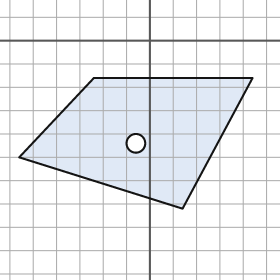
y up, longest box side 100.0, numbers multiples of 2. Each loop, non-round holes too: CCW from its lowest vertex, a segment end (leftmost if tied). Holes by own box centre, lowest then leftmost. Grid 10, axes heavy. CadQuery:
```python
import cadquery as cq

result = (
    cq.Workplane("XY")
    .moveTo(14.0, -72.0)
    .lineTo(44.0, -16.0)
    .lineTo(-24.0, -16.0)
    .lineTo(-56.0, -50.0)
    .close()
    .moveTo(-6.0, -44.0)
    .circle(4.0)
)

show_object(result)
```